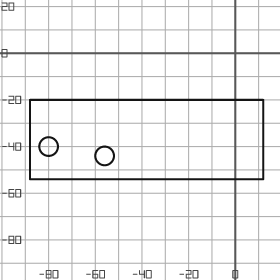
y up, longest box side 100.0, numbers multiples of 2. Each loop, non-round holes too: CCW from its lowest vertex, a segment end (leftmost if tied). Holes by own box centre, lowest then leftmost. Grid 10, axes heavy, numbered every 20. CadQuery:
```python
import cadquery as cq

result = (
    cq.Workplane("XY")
    .moveTo(-88.0, -54.0)
    .lineTo(12.0, -54.0)
    .lineTo(12.0, -20.0)
    .lineTo(-88.0, -20.0)
    .close()
    .moveTo(-56.0, -44.0)
    .circle(4.0)
    .moveTo(-80.0, -40.0)
    .circle(4.0)
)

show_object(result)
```